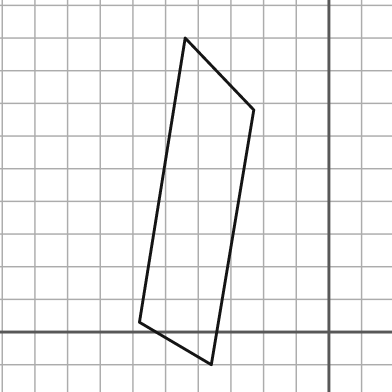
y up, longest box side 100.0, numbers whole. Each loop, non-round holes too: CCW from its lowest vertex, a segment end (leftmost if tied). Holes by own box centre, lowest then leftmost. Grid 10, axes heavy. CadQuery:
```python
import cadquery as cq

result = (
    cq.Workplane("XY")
    .moveTo(-36.0, -10.0)
    .lineTo(-23.0, 68.0)
    .lineTo(-44.0, 90.0)
    .lineTo(-58.0, 3.0)
    .close()
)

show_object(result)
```